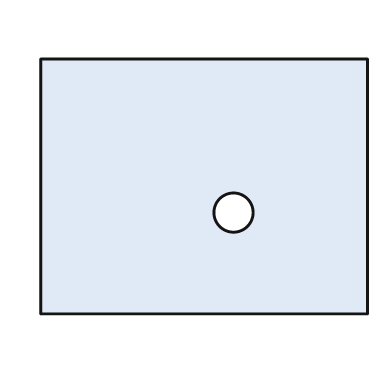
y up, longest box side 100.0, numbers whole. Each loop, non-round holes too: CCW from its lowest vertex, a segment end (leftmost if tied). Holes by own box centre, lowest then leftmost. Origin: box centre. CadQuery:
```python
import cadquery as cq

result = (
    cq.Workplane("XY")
    .moveTo(-50.0, -39.0)
    .lineTo(50.0, -39.0)
    .lineTo(50.0, 39.0)
    .lineTo(-50.0, 39.0)
    .close()
    .moveTo(9.0, -8.0)
    .circle(6.0)
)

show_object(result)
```